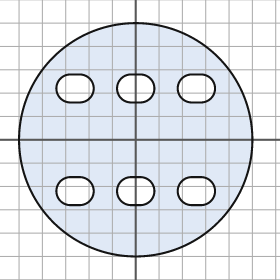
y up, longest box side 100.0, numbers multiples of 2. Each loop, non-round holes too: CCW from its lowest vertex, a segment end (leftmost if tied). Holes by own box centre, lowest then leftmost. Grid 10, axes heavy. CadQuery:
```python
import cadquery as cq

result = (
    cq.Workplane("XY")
    .moveTo(0.0, 0.0)
    .circle(50.0)
    .moveTo(-28.0, -28.0)
    .lineTo(-24.0, -28.0)
    .threePointArc((-18.0, -22.0), (-24.0, -16.0))
    .lineTo(-28.0, -16.0)
    .threePointArc((-34.0, -22.0), (-28.0, -28.0))
    .close()
    .moveTo(-2.0, -28.0)
    .lineTo(2.0, -28.0)
    .threePointArc((8.0, -22.0), (2.0, -16.0))
    .lineTo(-2.0, -16.0)
    .threePointArc((-8.0, -22.0), (-2.0, -28.0))
    .close()
    .moveTo(24.0, -28.0)
    .lineTo(28.0, -28.0)
    .threePointArc((34.0, -22.0), (28.0, -16.0))
    .lineTo(24.0, -16.0)
    .threePointArc((18.0, -22.0), (24.0, -28.0))
    .close()
    .moveTo(-28.0, 16.0)
    .lineTo(-24.0, 16.0)
    .threePointArc((-18.0, 22.0), (-24.0, 28.0))
    .lineTo(-28.0, 28.0)
    .threePointArc((-34.0, 22.0), (-28.0, 16.0))
    .close()
    .moveTo(-2.0, 16.0)
    .lineTo(2.0, 16.0)
    .threePointArc((8.0, 22.0), (2.0, 28.0))
    .lineTo(-2.0, 28.0)
    .threePointArc((-8.0, 22.0), (-2.0, 16.0))
    .close()
    .moveTo(24.0, 16.0)
    .lineTo(28.0, 16.0)
    .threePointArc((34.0, 22.0), (28.0, 28.0))
    .lineTo(24.0, 28.0)
    .threePointArc((18.0, 22.0), (24.0, 16.0))
    .close()
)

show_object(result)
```